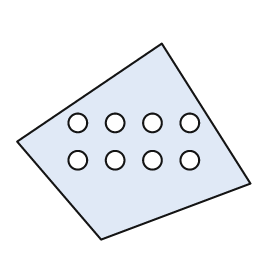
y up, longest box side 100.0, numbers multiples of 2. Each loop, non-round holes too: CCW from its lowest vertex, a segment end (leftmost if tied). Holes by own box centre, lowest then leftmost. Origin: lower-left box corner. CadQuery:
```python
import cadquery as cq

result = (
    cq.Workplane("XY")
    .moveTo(36.0, 0.0)
    .lineTo(100.0, 24.0)
    .lineTo(62.0, 84.0)
    .lineTo(0.0, 42.0)
    .close()
    .moveTo(26.0, 34.0)
    .circle(4.0)
    .moveTo(42.0, 34.0)
    .circle(4.0)
    .moveTo(58.0, 34.0)
    .circle(4.0)
    .moveTo(74.0, 34.0)
    .circle(4.0)
    .moveTo(26.0, 50.0)
    .circle(4.0)
    .moveTo(42.0, 50.0)
    .circle(4.0)
    .moveTo(58.0, 50.0)
    .circle(4.0)
    .moveTo(74.0, 50.0)
    .circle(4.0)
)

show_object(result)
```